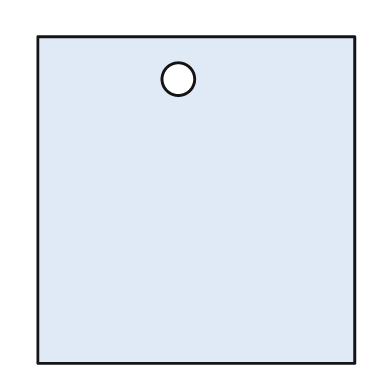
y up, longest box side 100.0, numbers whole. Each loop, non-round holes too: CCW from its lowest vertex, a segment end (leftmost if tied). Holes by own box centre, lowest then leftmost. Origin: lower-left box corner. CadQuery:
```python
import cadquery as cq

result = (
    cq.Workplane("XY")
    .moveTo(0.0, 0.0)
    .lineTo(97.0, 0.0)
    .lineTo(97.0, 100.0)
    .lineTo(0.0, 100.0)
    .close()
    .moveTo(43.0, 87.0)
    .circle(5.0)
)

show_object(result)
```